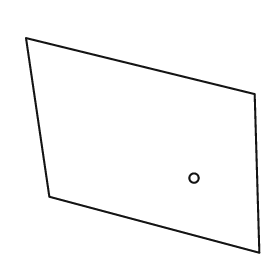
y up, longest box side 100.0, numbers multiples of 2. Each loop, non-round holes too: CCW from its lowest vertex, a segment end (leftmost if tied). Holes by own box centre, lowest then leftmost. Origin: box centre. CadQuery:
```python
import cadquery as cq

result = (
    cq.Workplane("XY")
    .moveTo(50.0, -46.0)
    .lineTo(48.0, 22.0)
    .lineTo(-50.0, 46.0)
    .lineTo(-40.0, -22.0)
    .close()
    .moveTo(22.0, -14.0)
    .circle(2.0)
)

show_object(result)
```